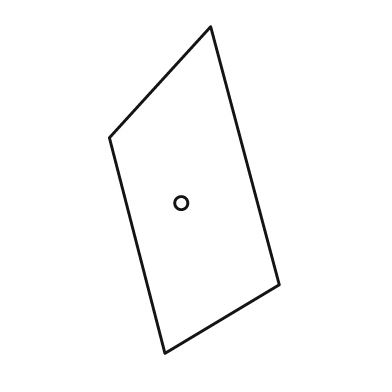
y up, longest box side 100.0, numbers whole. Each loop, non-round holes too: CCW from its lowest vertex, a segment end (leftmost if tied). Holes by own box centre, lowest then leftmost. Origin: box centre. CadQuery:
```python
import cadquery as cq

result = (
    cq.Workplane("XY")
    .moveTo(-9.0, -50.0)
    .lineTo(26.0, -29.0)
    .lineTo(5.0, 50.0)
    .lineTo(-26.0, 16.0)
    .close()
    .moveTo(-4.0, -4.0)
    .circle(2.0)
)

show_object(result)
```